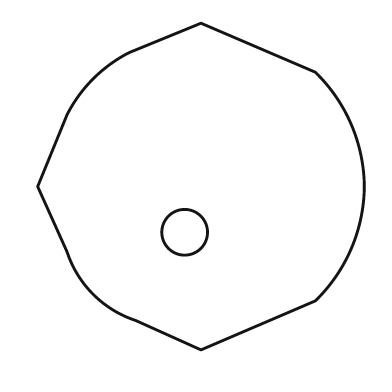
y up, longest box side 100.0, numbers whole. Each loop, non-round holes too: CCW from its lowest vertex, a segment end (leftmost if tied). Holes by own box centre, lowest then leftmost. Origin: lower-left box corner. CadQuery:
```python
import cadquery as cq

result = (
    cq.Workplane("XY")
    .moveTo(50.0, 0.0)
    .lineTo(85.0, 15.0)
    .threePointArc((96.0, 31.0), (100.0, 50.0))
    .threePointArc((96.0, 69.0), (85.0, 85.0))
    .lineTo(50.0, 100.0)
    .lineTo(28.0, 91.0)
    .threePointArc((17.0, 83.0), (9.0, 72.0))
    .lineTo(0.0, 50.0)
    .lineTo(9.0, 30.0)
    .threePointArc((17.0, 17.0), (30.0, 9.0))
    .close()
    .moveTo(45.0, 36.0)
    .circle(7.0)
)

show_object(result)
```